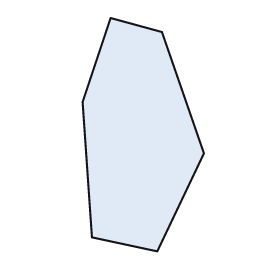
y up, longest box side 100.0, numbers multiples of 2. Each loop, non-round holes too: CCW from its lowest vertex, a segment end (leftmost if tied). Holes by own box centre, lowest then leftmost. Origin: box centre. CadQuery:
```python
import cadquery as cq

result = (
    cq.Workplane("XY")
    .moveTo(6.0, -50.0)
    .lineTo(26.0, -8.0)
    .lineTo(8.0, 44.0)
    .lineTo(-14.0, 50.0)
    .lineTo(-26.0, 14.0)
    .lineTo(-22.0, -44.0)
    .close()
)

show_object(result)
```